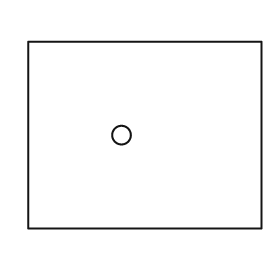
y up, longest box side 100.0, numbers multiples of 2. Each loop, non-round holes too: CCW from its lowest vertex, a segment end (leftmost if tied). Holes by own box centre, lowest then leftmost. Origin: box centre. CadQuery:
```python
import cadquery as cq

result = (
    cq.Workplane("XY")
    .moveTo(-50.0, -40.0)
    .lineTo(50.0, -40.0)
    .lineTo(50.0, 40.0)
    .lineTo(-50.0, 40.0)
    .close()
    .moveTo(-10.0, 0.0)
    .circle(4.0)
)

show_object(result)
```